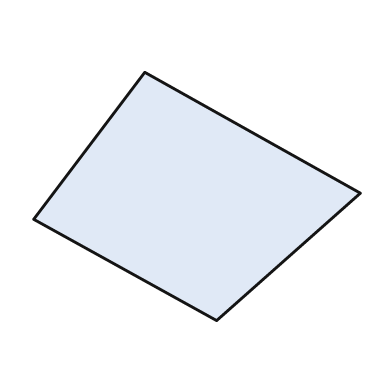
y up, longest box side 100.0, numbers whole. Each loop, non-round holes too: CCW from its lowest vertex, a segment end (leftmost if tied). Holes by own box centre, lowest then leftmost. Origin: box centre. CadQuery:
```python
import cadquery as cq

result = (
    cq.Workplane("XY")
    .moveTo(6.0, -38.0)
    .lineTo(50.0, 1.0)
    .lineTo(-16.0, 38.0)
    .lineTo(-50.0, -7.0)
    .close()
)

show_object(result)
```